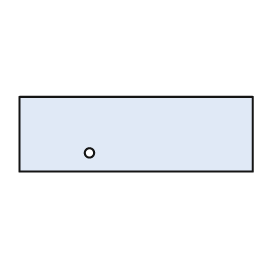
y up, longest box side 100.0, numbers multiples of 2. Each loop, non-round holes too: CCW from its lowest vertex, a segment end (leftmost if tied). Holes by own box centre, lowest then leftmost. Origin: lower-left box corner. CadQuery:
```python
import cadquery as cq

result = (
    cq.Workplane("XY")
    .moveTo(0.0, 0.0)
    .lineTo(100.0, 0.0)
    .lineTo(100.0, 32.0)
    .lineTo(0.0, 32.0)
    .close()
    .moveTo(30.0, 8.0)
    .circle(2.0)
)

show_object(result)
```